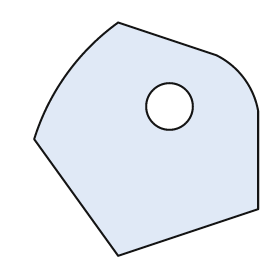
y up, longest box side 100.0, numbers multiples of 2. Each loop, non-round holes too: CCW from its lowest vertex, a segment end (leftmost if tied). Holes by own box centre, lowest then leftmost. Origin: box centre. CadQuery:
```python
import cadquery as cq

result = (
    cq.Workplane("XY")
    .moveTo(-12.0, -50.0)
    .lineTo(48.0, -30.0)
    .lineTo(48.0, 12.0)
    .threePointArc((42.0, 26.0), (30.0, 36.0))
    .lineTo(-12.0, 50.0)
    .threePointArc((-34.0, 28.0), (-48.0, 0.0))
    .close()
    .moveTo(10.0, 14.0)
    .circle(10.0)
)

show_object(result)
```